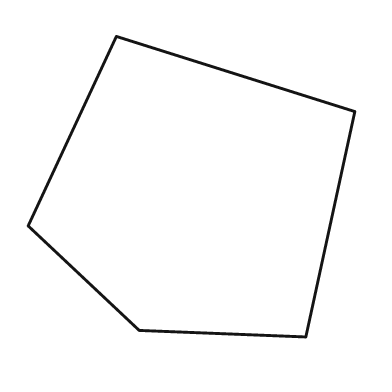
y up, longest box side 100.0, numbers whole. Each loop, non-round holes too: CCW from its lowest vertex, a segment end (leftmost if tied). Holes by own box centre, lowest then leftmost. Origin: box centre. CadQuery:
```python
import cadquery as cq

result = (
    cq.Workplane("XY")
    .moveTo(35.0, -46.0)
    .lineTo(50.0, 23.0)
    .lineTo(-23.0, 46.0)
    .lineTo(-50.0, -12.0)
    .lineTo(-16.0, -44.0)
    .close()
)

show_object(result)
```